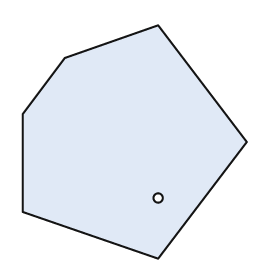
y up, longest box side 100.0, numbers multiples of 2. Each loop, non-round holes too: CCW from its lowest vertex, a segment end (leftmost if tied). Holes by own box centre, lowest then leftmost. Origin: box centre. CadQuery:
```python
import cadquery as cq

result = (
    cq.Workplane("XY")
    .moveTo(10.0, -50.0)
    .lineTo(48.0, 0.0)
    .lineTo(10.0, 50.0)
    .lineTo(-30.0, 36.0)
    .lineTo(-48.0, 12.0)
    .lineTo(-48.0, -30.0)
    .close()
    .moveTo(10.0, -24.0)
    .circle(2.0)
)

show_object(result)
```